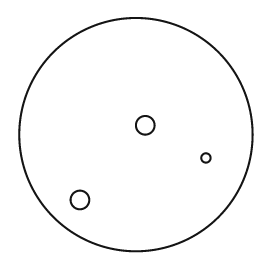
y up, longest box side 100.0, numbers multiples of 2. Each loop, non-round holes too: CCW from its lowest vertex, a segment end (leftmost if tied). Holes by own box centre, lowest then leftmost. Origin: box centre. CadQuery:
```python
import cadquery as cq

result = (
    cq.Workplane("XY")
    .moveTo(0.0, 0.0)
    .circle(50.0)
    .moveTo(-24.0, -28.0)
    .circle(4.0)
    .moveTo(30.0, -10.0)
    .circle(2.0)
    .moveTo(4.0, 4.0)
    .circle(4.0)
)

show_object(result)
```